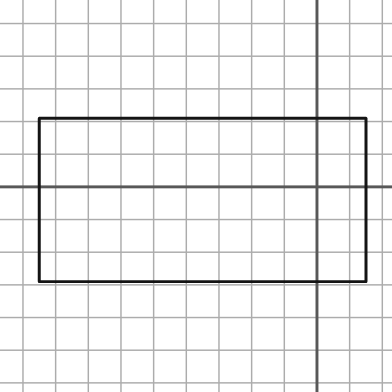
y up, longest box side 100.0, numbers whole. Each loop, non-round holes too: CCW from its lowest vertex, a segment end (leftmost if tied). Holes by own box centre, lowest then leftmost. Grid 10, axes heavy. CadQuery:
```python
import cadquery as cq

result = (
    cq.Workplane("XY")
    .moveTo(-85.0, -29.0)
    .lineTo(15.0, -29.0)
    .lineTo(15.0, 21.0)
    .lineTo(-85.0, 21.0)
    .close()
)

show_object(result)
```